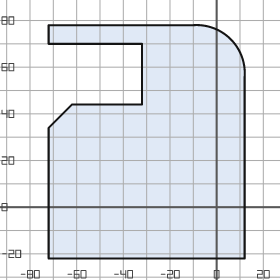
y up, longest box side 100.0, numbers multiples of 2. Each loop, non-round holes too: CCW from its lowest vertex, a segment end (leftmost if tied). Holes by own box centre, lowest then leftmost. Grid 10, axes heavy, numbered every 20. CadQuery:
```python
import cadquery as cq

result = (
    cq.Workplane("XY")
    .moveTo(-72.0, -22.0)
    .lineTo(12.0, -22.0)
    .lineTo(12.0, 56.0)
    .threePointArc((6.0, 72.0), (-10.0, 78.0))
    .lineTo(-72.0, 78.0)
    .lineTo(-72.0, 70.0)
    .lineTo(-32.0, 70.0)
    .lineTo(-32.0, 44.0)
    .lineTo(-62.0, 44.0)
    .lineTo(-72.0, 34.0)
    .close()
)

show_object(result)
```